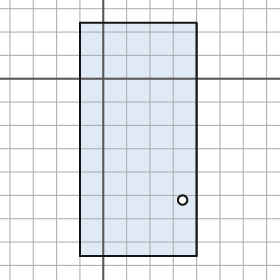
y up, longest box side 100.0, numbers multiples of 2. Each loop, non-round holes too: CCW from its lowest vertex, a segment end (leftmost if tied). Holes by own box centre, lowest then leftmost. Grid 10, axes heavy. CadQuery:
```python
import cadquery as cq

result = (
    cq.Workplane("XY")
    .moveTo(-10.0, -76.0)
    .lineTo(40.0, -76.0)
    .lineTo(40.0, 24.0)
    .lineTo(-10.0, 24.0)
    .close()
    .moveTo(34.0, -52.0)
    .circle(2.0)
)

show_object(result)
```